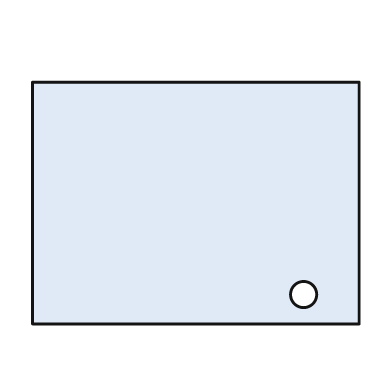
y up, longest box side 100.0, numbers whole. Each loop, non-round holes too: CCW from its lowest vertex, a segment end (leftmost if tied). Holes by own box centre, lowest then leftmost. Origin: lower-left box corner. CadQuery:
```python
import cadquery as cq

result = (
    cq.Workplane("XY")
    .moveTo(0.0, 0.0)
    .lineTo(100.0, 0.0)
    .lineTo(100.0, 74.0)
    .lineTo(0.0, 74.0)
    .close()
    .moveTo(83.0, 9.0)
    .circle(4.0)
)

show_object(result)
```